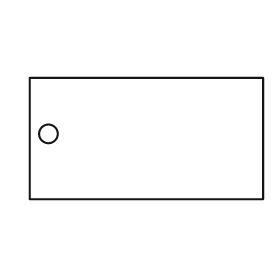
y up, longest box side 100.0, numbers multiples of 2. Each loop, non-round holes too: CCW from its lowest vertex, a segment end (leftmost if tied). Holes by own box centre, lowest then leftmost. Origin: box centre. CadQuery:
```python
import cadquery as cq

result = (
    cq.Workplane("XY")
    .moveTo(-50.0, -26.0)
    .lineTo(50.0, -26.0)
    .lineTo(50.0, 26.0)
    .lineTo(-50.0, 26.0)
    .close()
    .moveTo(-42.0, 2.0)
    .circle(4.0)
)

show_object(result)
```